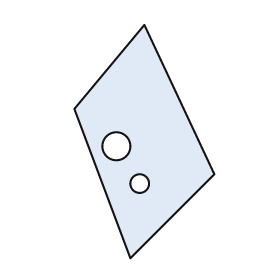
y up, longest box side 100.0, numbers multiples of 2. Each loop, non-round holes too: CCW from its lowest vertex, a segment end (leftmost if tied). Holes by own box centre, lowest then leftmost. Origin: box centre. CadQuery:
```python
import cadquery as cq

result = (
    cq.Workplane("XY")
    .moveTo(-6.0, -50.0)
    .lineTo(30.0, -14.0)
    .lineTo(0.0, 50.0)
    .lineTo(-30.0, 14.0)
    .close()
    .moveTo(-2.0, -18.0)
    .circle(4.0)
    .moveTo(-12.0, -2.0)
    .circle(6.0)
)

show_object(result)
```